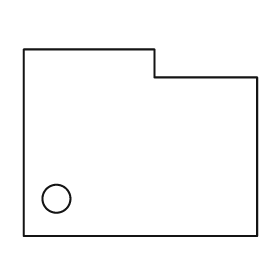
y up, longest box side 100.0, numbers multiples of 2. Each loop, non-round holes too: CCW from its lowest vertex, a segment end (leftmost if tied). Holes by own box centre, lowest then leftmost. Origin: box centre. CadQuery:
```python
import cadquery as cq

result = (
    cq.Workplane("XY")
    .moveTo(-50.0, -40.0)
    .lineTo(50.0, -40.0)
    .lineTo(50.0, 28.0)
    .lineTo(6.0, 28.0)
    .lineTo(6.0, 40.0)
    .lineTo(-50.0, 40.0)
    .close()
    .moveTo(-36.0, -24.0)
    .circle(6.0)
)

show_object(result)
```